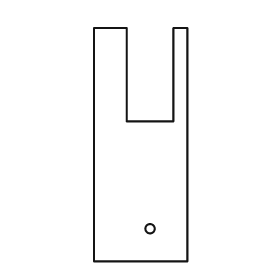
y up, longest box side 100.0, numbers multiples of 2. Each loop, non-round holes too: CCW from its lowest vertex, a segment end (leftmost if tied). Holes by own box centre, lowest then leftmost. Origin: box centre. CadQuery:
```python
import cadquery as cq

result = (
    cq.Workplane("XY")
    .moveTo(-20.0, -50.0)
    .lineTo(20.0, -50.0)
    .lineTo(20.0, 50.0)
    .lineTo(14.0, 50.0)
    .lineTo(14.0, 10.0)
    .lineTo(-6.0, 10.0)
    .lineTo(-6.0, 50.0)
    .lineTo(-20.0, 50.0)
    .close()
    .moveTo(4.0, -36.0)
    .circle(2.0)
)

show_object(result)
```